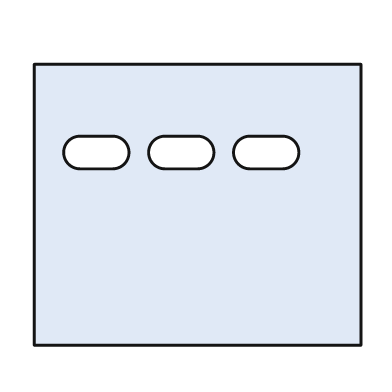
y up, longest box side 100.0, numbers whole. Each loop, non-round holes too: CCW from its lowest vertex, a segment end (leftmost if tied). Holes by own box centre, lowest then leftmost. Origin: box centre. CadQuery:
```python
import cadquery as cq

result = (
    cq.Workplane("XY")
    .moveTo(-50.0, -43.0)
    .lineTo(50.0, -43.0)
    .lineTo(50.0, 43.0)
    .lineTo(-50.0, 43.0)
    .close()
    .moveTo(-36.0, 11.0)
    .lineTo(-26.0, 11.0)
    .threePointArc((-21.0, 16.0), (-26.0, 21.0))
    .lineTo(-36.0, 21.0)
    .threePointArc((-41.0, 16.0), (-36.0, 11.0))
    .close()
    .moveTo(-10.0, 11.0)
    .lineTo(0.0, 11.0)
    .threePointArc((5.0, 16.0), (0.0, 21.0))
    .lineTo(-10.0, 21.0)
    .threePointArc((-15.0, 16.0), (-10.0, 11.0))
    .close()
    .moveTo(16.0, 11.0)
    .lineTo(26.0, 11.0)
    .threePointArc((31.0, 16.0), (26.0, 21.0))
    .lineTo(16.0, 21.0)
    .threePointArc((11.0, 16.0), (16.0, 11.0))
    .close()
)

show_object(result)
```